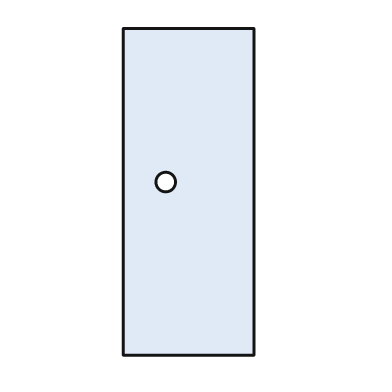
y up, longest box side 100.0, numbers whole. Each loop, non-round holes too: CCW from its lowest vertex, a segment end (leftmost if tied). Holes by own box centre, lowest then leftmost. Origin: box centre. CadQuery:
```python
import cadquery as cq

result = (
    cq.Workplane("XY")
    .moveTo(-20.0, -50.0)
    .lineTo(20.0, -50.0)
    .lineTo(20.0, 50.0)
    .lineTo(-20.0, 50.0)
    .close()
    .moveTo(-7.0, 3.0)
    .circle(3.0)
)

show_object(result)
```